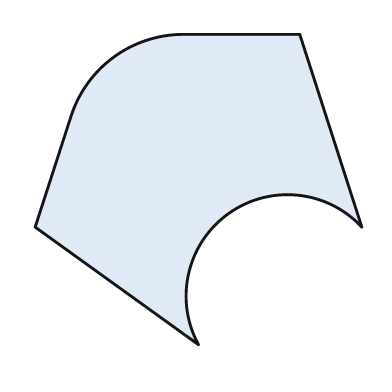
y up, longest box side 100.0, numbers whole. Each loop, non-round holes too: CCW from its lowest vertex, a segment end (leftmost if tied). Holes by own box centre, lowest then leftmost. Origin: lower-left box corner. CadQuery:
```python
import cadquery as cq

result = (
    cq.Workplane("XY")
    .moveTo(50.0, 0.0)
    .threePointArc((59.0, 40.0), (100.0, 36.0))
    .lineTo(81.0, 95.0)
    .lineTo(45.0, 95.0)
    .threePointArc((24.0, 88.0), (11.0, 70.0))
    .lineTo(0.0, 36.0)
    .close()
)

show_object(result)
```